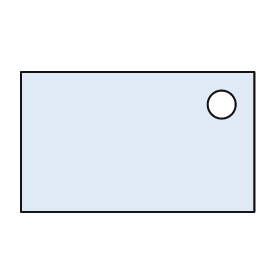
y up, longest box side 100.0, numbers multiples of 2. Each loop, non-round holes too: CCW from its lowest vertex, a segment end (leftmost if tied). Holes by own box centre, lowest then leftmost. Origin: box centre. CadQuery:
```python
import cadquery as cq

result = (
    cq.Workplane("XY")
    .moveTo(-50.0, -30.0)
    .lineTo(50.0, -30.0)
    .lineTo(50.0, 30.0)
    .lineTo(-50.0, 30.0)
    .close()
    .moveTo(36.0, 16.0)
    .circle(6.0)
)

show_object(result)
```